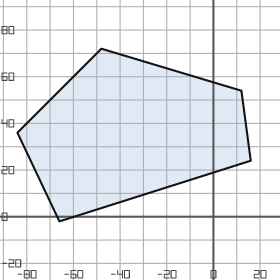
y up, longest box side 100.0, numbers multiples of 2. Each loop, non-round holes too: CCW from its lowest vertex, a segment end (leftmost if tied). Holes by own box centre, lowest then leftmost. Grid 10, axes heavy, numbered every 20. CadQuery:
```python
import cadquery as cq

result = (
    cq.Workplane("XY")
    .moveTo(-66.0, -2.0)
    .lineTo(16.0, 24.0)
    .lineTo(12.0, 54.0)
    .lineTo(-48.0, 72.0)
    .lineTo(-84.0, 36.0)
    .close()
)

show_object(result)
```